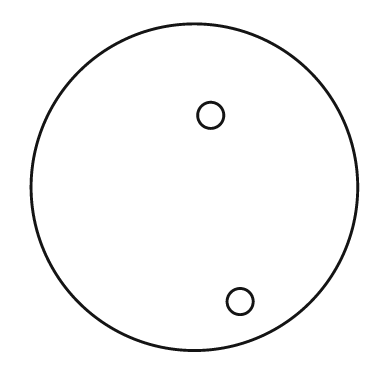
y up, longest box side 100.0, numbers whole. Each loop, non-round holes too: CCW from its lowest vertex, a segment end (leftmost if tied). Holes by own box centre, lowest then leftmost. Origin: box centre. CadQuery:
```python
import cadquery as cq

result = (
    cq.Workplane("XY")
    .moveTo(0.0, 0.0)
    .circle(50.0)
    .moveTo(14.0, -35.0)
    .circle(4.0)
    .moveTo(5.0, 22.0)
    .circle(4.0)
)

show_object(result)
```